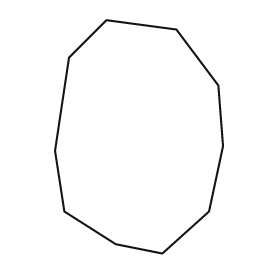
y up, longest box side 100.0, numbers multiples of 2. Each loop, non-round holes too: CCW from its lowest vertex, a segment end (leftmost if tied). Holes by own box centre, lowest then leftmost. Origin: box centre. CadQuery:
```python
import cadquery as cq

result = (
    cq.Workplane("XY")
    .moveTo(10.0, -50.0)
    .lineTo(30.0, -32.0)
    .lineTo(36.0, -4.0)
    .lineTo(34.0, 22.0)
    .lineTo(16.0, 46.0)
    .lineTo(-14.0, 50.0)
    .lineTo(-30.0, 34.0)
    .lineTo(-36.0, -6.0)
    .lineTo(-32.0, -32.0)
    .lineTo(-10.0, -46.0)
    .close()
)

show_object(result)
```